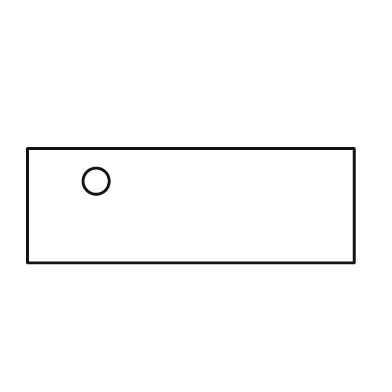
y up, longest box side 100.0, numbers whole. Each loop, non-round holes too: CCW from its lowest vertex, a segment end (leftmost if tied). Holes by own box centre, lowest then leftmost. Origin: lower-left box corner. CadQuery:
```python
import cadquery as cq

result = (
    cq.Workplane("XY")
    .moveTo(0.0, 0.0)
    .lineTo(100.0, 0.0)
    .lineTo(100.0, 35.0)
    .lineTo(0.0, 35.0)
    .close()
    .moveTo(21.0, 25.0)
    .circle(4.0)
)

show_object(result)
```